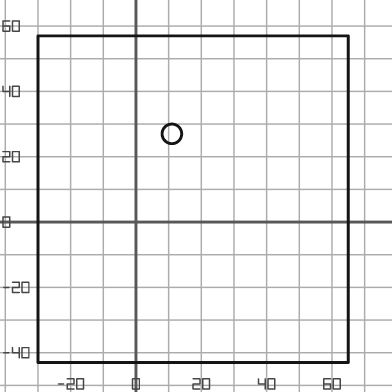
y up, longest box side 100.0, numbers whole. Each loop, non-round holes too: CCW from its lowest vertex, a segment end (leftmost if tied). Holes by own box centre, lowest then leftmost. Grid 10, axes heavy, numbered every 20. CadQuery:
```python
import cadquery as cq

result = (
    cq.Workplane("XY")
    .moveTo(-30.0, -43.0)
    .lineTo(65.0, -43.0)
    .lineTo(65.0, 57.0)
    .lineTo(-30.0, 57.0)
    .close()
    .moveTo(11.0, 27.0)
    .circle(3.0)
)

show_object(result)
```